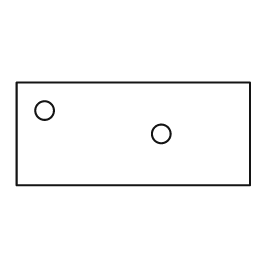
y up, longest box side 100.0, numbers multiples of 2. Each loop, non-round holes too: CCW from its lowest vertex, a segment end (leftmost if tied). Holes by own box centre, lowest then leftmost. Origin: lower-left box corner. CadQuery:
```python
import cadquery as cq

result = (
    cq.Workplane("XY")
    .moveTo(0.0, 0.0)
    .lineTo(100.0, 0.0)
    .lineTo(100.0, 44.0)
    .lineTo(0.0, 44.0)
    .close()
    .moveTo(62.0, 22.0)
    .circle(4.0)
    .moveTo(12.0, 32.0)
    .circle(4.0)
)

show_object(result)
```